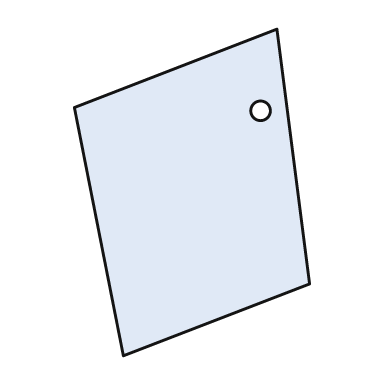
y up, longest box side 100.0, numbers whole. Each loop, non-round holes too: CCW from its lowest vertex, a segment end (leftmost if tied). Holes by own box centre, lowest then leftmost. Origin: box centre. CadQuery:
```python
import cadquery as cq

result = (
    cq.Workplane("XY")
    .moveTo(-21.0, -50.0)
    .lineTo(36.0, -28.0)
    .lineTo(26.0, 50.0)
    .lineTo(-36.0, 26.0)
    .close()
    .moveTo(21.0, 25.0)
    .circle(3.0)
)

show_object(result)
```